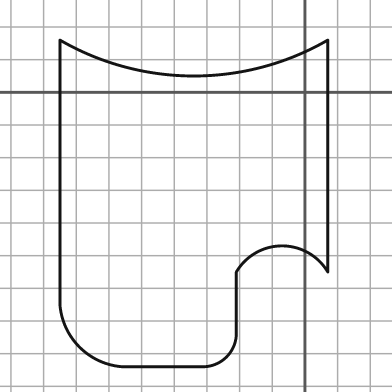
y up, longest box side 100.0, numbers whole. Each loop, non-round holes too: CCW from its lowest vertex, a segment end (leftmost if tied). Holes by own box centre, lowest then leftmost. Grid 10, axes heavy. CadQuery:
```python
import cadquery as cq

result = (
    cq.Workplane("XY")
    .moveTo(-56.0, -84.0)
    .lineTo(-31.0, -84.0)
    .threePointArc((-24.0, -81.0), (-21.0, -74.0))
    .lineTo(-21.0, -55.0)
    .threePointArc((-7.0, -47.0), (7.0, -55.0))
    .lineTo(7.0, 16.0)
    .threePointArc((-34.0, 5.0), (-75.0, 16.0))
    .lineTo(-75.0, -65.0)
    .threePointArc((-69.0, -78.0), (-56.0, -84.0))
    .close()
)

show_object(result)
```